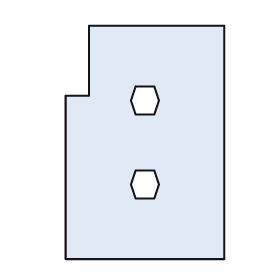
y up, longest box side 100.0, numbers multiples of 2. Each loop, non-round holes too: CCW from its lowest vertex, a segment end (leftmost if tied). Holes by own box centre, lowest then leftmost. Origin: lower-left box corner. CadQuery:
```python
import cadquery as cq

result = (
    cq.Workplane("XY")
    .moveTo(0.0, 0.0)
    .lineTo(68.0, 0.0)
    .lineTo(68.0, 100.0)
    .lineTo(10.0, 100.0)
    .lineTo(10.0, 70.0)
    .lineTo(0.0, 70.0)
    .close()
    .moveTo(30.0, 26.0)
    .lineTo(38.0, 26.0)
    .lineTo(40.0, 32.0)
    .lineTo(38.0, 38.0)
    .lineTo(30.0, 38.0)
    .lineTo(28.0, 32.0)
    .close()
    .moveTo(30.0, 62.0)
    .lineTo(38.0, 62.0)
    .lineTo(40.0, 68.0)
    .lineTo(38.0, 74.0)
    .lineTo(30.0, 74.0)
    .lineTo(28.0, 68.0)
    .close()
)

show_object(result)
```